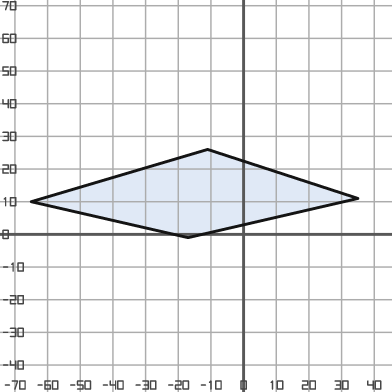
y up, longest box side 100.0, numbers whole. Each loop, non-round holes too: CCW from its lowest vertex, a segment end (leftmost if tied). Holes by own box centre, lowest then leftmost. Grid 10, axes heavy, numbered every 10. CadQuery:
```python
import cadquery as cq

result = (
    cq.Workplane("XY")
    .moveTo(-17.0, -1.0)
    .lineTo(35.0, 11.0)
    .lineTo(-11.0, 26.0)
    .lineTo(-65.0, 10.0)
    .close()
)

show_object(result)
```